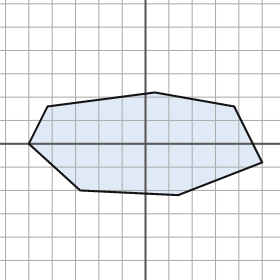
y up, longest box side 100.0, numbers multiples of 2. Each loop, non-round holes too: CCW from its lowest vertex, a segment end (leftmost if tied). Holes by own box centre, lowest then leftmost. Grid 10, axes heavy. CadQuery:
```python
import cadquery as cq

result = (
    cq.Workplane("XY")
    .moveTo(14.0, -22.0)
    .lineTo(50.0, -8.0)
    .lineTo(38.0, 16.0)
    .lineTo(4.0, 22.0)
    .lineTo(-42.0, 16.0)
    .lineTo(-50.0, 0.0)
    .lineTo(-28.0, -20.0)
    .close()
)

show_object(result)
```